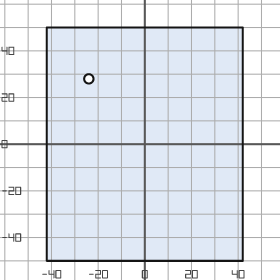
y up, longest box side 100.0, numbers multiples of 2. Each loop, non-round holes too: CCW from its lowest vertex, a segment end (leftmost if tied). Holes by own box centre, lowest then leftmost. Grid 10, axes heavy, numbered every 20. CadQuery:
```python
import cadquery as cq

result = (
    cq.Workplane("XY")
    .moveTo(-42.0, -50.0)
    .lineTo(42.0, -50.0)
    .lineTo(42.0, 50.0)
    .lineTo(-42.0, 50.0)
    .close()
    .moveTo(-24.0, 28.0)
    .circle(2.0)
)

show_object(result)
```